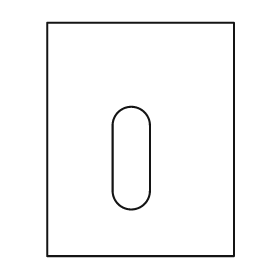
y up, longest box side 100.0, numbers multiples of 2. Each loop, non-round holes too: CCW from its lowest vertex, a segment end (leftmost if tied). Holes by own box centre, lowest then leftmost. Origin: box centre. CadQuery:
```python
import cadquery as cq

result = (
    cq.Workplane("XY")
    .moveTo(-40.0, -50.0)
    .lineTo(40.0, -50.0)
    .lineTo(40.0, 50.0)
    .lineTo(-40.0, 50.0)
    .close()
    .moveTo(-12.0, -22.0)
    .threePointArc((-4.0, -30.0), (4.0, -22.0))
    .lineTo(4.0, 6.0)
    .threePointArc((-4.0, 14.0), (-12.0, 6.0))
    .close()
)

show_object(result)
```